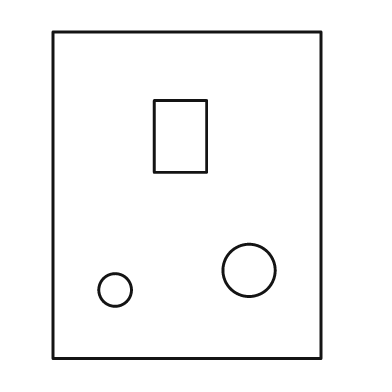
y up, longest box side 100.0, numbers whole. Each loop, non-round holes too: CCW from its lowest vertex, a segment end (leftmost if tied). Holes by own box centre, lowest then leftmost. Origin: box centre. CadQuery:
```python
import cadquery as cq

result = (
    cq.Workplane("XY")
    .moveTo(-41.0, -50.0)
    .lineTo(41.0, -50.0)
    .lineTo(41.0, 50.0)
    .lineTo(-41.0, 50.0)
    .close()
    .moveTo(-22.0, -29.0)
    .circle(5.0)
    .moveTo(19.0, -23.0)
    .circle(8.0)
    .moveTo(-10.0, 7.0)
    .lineTo(6.0, 7.0)
    .lineTo(6.0, 29.0)
    .lineTo(-10.0, 29.0)
    .close()
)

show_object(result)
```